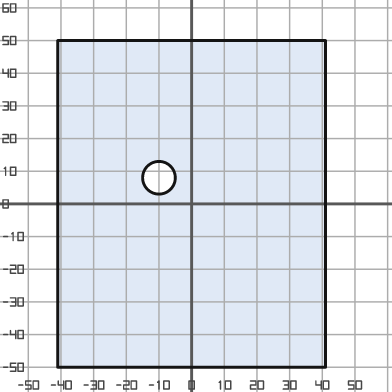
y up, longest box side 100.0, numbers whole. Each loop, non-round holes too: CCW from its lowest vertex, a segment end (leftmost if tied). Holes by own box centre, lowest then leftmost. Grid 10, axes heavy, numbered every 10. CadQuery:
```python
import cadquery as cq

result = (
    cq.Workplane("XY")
    .moveTo(-41.0, -50.0)
    .lineTo(41.0, -50.0)
    .lineTo(41.0, 50.0)
    .lineTo(-41.0, 50.0)
    .close()
    .moveTo(-10.0, 8.0)
    .circle(5.0)
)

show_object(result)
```